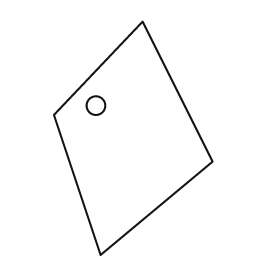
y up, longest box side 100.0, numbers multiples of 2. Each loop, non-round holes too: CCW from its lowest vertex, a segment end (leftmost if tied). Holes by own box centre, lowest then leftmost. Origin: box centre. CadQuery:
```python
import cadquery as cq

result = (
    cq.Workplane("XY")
    .moveTo(-14.0, -50.0)
    .lineTo(34.0, -10.0)
    .lineTo(4.0, 50.0)
    .lineTo(-34.0, 10.0)
    .close()
    .moveTo(-16.0, 14.0)
    .circle(4.0)
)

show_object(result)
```